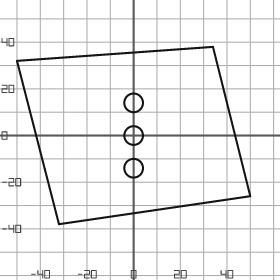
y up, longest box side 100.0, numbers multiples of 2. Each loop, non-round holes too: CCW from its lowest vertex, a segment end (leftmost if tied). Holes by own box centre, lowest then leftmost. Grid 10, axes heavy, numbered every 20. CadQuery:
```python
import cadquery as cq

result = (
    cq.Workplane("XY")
    .moveTo(-32.0, -38.0)
    .lineTo(50.0, -26.0)
    .lineTo(34.0, 38.0)
    .lineTo(-50.0, 32.0)
    .close()
    .moveTo(0.0, -14.0)
    .circle(4.0)
    .moveTo(0.0, 0.0)
    .circle(4.0)
    .moveTo(0.0, 14.0)
    .circle(4.0)
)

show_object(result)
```